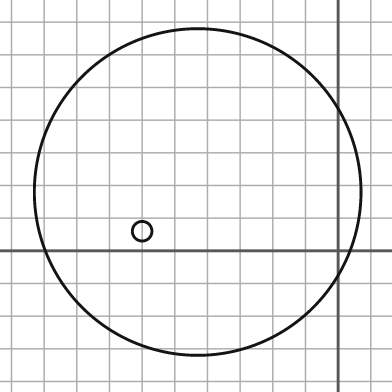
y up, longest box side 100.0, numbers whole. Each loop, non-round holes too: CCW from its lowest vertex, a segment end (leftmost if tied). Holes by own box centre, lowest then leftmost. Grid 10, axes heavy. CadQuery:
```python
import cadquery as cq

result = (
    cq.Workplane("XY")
    .moveTo(-43.0, 18.0)
    .circle(50.0)
    .moveTo(-60.0, 6.0)
    .circle(3.0)
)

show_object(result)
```